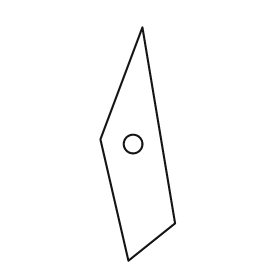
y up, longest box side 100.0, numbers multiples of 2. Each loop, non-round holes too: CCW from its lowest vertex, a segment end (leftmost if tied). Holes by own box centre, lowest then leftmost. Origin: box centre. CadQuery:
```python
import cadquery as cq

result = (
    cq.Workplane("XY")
    .moveTo(-4.0, -50.0)
    .lineTo(16.0, -34.0)
    .lineTo(2.0, 50.0)
    .lineTo(-16.0, 2.0)
    .close()
    .moveTo(-2.0, 0.0)
    .circle(4.0)
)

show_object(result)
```